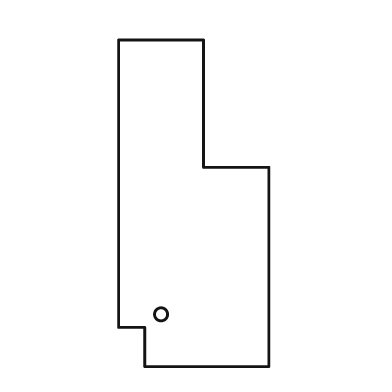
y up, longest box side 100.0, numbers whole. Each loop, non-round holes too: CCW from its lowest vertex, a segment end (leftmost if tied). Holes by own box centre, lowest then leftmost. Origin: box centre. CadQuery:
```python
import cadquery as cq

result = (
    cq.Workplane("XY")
    .moveTo(-15.0, -50.0)
    .lineTo(23.0, -50.0)
    .lineTo(23.0, 11.0)
    .lineTo(3.0, 11.0)
    .lineTo(3.0, 50.0)
    .lineTo(-23.0, 50.0)
    .lineTo(-23.0, -38.0)
    .lineTo(-15.0, -38.0)
    .close()
    .moveTo(-10.0, -34.0)
    .circle(2.0)
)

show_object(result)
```